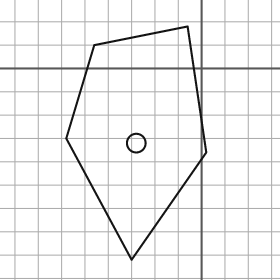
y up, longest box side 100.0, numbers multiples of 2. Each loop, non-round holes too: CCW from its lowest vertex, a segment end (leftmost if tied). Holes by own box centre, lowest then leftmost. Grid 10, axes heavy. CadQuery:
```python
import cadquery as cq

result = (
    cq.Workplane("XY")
    .moveTo(-30.0, -82.0)
    .lineTo(2.0, -36.0)
    .lineTo(-6.0, 18.0)
    .lineTo(-46.0, 10.0)
    .lineTo(-58.0, -30.0)
    .close()
    .moveTo(-28.0, -32.0)
    .circle(4.0)
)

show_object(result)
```